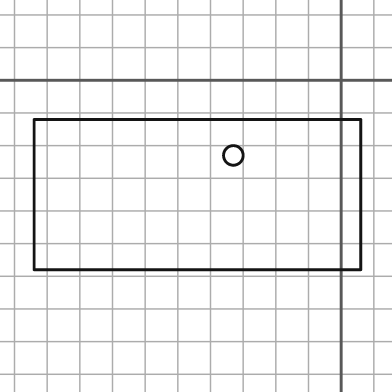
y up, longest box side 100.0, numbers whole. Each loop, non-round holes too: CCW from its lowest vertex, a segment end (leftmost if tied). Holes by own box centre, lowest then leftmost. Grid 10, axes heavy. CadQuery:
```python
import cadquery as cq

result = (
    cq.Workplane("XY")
    .moveTo(-94.0, -58.0)
    .lineTo(6.0, -58.0)
    .lineTo(6.0, -12.0)
    .lineTo(-94.0, -12.0)
    .close()
    .moveTo(-33.0, -23.0)
    .circle(3.0)
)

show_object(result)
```